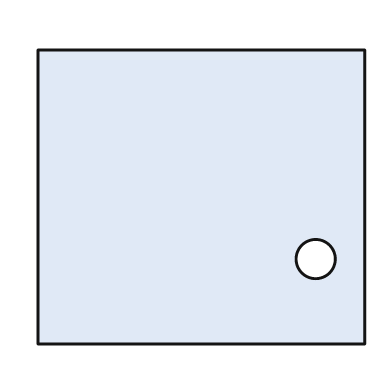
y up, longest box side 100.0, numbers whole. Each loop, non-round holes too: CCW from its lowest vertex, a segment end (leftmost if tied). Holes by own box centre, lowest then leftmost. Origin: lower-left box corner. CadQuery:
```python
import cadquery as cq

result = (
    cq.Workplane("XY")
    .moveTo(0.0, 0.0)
    .lineTo(100.0, 0.0)
    .lineTo(100.0, 90.0)
    .lineTo(0.0, 90.0)
    .close()
    .moveTo(85.0, 26.0)
    .circle(6.0)
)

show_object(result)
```